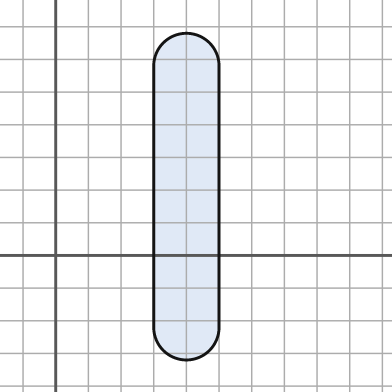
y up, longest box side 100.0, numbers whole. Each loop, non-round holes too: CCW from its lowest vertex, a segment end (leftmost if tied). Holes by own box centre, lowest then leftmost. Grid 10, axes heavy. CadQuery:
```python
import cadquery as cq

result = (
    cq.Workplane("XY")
    .moveTo(30.0, -22.0)
    .threePointArc((40.0, -32.0), (50.0, -22.0))
    .lineTo(50.0, 58.0)
    .threePointArc((40.0, 68.0), (30.0, 58.0))
    .close()
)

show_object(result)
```